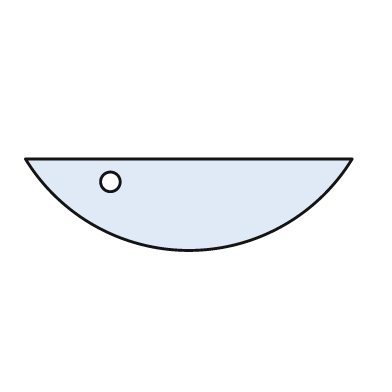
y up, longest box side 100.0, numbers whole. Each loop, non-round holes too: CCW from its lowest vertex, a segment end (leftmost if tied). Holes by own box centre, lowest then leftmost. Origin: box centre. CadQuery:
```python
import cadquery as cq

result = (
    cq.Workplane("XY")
    .moveTo(-50.0, 14.0)
    .threePointArc((0.0, -14.0), (50.0, 14.0))
    .close()
    .moveTo(-24.0, 7.0)
    .circle(3.0)
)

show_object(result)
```